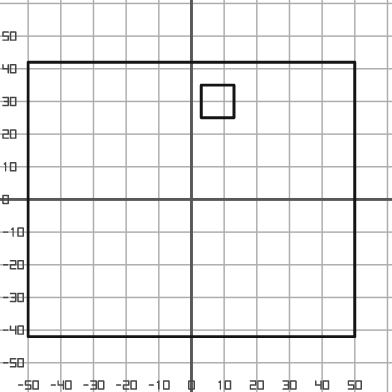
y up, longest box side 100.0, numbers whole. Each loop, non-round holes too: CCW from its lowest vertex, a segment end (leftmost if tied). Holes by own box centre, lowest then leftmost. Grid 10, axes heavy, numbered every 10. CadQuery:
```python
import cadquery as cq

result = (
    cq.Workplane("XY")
    .moveTo(-50.0, -42.0)
    .lineTo(50.0, -42.0)
    .lineTo(50.0, 42.0)
    .lineTo(-50.0, 42.0)
    .close()
    .moveTo(3.0, 25.0)
    .lineTo(13.0, 25.0)
    .lineTo(13.0, 35.0)
    .lineTo(3.0, 35.0)
    .close()
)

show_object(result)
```